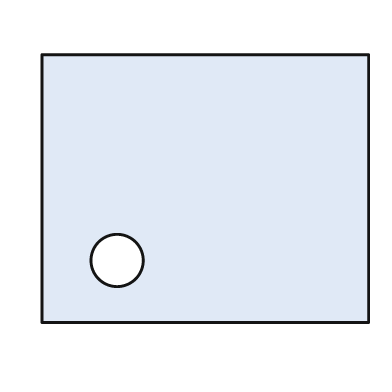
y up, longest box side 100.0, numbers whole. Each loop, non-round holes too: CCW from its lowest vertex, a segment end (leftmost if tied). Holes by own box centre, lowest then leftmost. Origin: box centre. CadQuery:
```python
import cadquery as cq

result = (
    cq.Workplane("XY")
    .moveTo(-50.0, -41.0)
    .lineTo(50.0, -41.0)
    .lineTo(50.0, 41.0)
    .lineTo(-50.0, 41.0)
    .close()
    .moveTo(-27.0, -22.0)
    .circle(8.0)
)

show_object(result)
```